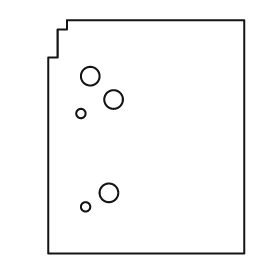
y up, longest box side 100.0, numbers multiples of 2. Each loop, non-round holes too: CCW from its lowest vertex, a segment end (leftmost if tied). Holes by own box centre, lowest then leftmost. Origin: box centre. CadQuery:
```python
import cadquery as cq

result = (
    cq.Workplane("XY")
    .moveTo(-42.0, -50.0)
    .lineTo(42.0, -50.0)
    .lineTo(42.0, 50.0)
    .lineTo(-34.0, 50.0)
    .lineTo(-34.0, 46.0)
    .lineTo(-38.0, 46.0)
    .lineTo(-38.0, 34.0)
    .lineTo(-42.0, 34.0)
    .close()
    .moveTo(-26.0, -30.0)
    .circle(2.0)
    .moveTo(-16.0, -24.0)
    .circle(4.0)
    .moveTo(-28.0, 10.0)
    .circle(2.0)
    .moveTo(-14.0, 16.0)
    .circle(4.0)
    .moveTo(-24.0, 26.0)
    .circle(4.0)
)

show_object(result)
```